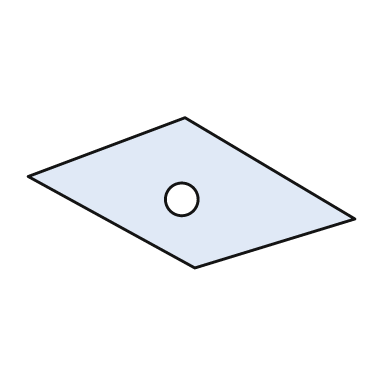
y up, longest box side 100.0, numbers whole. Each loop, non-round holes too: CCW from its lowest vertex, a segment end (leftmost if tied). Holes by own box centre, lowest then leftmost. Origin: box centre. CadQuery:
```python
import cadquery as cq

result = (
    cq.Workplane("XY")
    .moveTo(1.0, -23.0)
    .lineTo(50.0, -8.0)
    .lineTo(-2.0, 23.0)
    .lineTo(-50.0, 5.0)
    .close()
    .moveTo(-3.0, -2.0)
    .circle(5.0)
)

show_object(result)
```